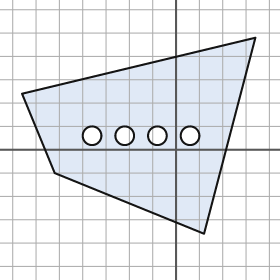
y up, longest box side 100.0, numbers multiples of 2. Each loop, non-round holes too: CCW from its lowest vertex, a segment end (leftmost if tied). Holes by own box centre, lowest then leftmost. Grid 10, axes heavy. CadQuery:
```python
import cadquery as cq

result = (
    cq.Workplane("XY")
    .moveTo(12.0, -36.0)
    .lineTo(34.0, 48.0)
    .lineTo(-66.0, 24.0)
    .lineTo(-52.0, -10.0)
    .close()
    .moveTo(-36.0, 6.0)
    .circle(4.0)
    .moveTo(-22.0, 6.0)
    .circle(4.0)
    .moveTo(-8.0, 6.0)
    .circle(4.0)
    .moveTo(6.0, 6.0)
    .circle(4.0)
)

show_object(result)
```